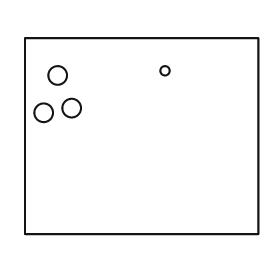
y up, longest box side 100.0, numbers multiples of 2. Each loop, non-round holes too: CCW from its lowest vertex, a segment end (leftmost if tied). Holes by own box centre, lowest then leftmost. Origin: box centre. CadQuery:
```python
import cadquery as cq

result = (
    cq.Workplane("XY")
    .moveTo(-50.0, -42.0)
    .lineTo(50.0, -42.0)
    .lineTo(50.0, 42.0)
    .lineTo(-50.0, 42.0)
    .close()
    .moveTo(-42.0, 10.0)
    .circle(4.0)
    .moveTo(-30.0, 12.0)
    .circle(4.0)
    .moveTo(-36.0, 26.0)
    .circle(4.0)
    .moveTo(10.0, 28.0)
    .circle(2.0)
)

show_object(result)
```